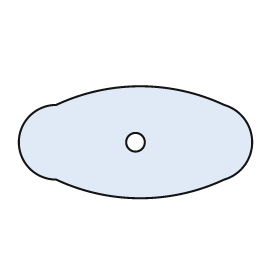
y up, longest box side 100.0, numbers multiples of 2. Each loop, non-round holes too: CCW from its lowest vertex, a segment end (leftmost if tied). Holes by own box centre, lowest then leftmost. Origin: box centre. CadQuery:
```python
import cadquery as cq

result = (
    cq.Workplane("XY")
    .moveTo(-34.0, -16.0)
    .threePointArc((2.0, -24.0), (38.0, -16.0))
    .threePointArc((50.0, 0.0), (38.0, 16.0))
    .threePointArc((2.0, 24.0), (-34.0, 16.0))
    .threePointArc((-50.0, 0.0), (-34.0, -16.0))
    .close()
    .moveTo(0.0, 0.0)
    .circle(4.0)
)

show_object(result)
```